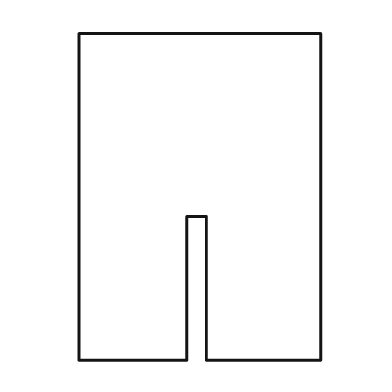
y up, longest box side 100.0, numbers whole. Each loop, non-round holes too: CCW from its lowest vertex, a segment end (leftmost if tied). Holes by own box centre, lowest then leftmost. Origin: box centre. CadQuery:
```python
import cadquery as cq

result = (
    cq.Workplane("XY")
    .moveTo(-37.0, -50.0)
    .lineTo(-4.0, -50.0)
    .lineTo(-4.0, -6.0)
    .lineTo(2.0, -6.0)
    .lineTo(2.0, -50.0)
    .lineTo(37.0, -50.0)
    .lineTo(37.0, 50.0)
    .lineTo(-37.0, 50.0)
    .close()
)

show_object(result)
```